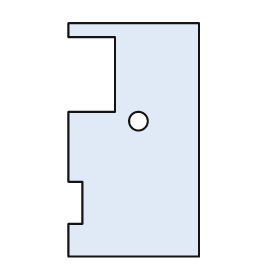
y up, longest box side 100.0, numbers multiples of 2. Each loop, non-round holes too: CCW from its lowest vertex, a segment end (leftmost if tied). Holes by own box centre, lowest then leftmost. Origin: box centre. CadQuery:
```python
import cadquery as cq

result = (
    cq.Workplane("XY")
    .moveTo(-28.0, -50.0)
    .lineTo(28.0, -50.0)
    .lineTo(28.0, 50.0)
    .lineTo(-28.0, 50.0)
    .lineTo(-28.0, 44.0)
    .lineTo(-8.0, 44.0)
    .lineTo(-8.0, 12.0)
    .lineTo(-28.0, 12.0)
    .lineTo(-28.0, -18.0)
    .lineTo(-22.0, -18.0)
    .lineTo(-22.0, -36.0)
    .lineTo(-28.0, -36.0)
    .close()
    .moveTo(2.0, 8.0)
    .circle(4.0)
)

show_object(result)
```